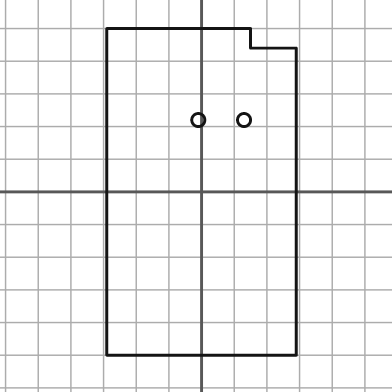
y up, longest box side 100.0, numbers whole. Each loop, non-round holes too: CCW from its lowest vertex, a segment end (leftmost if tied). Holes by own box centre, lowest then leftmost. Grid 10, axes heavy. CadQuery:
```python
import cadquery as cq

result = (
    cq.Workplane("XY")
    .moveTo(-29.0, -50.0)
    .lineTo(29.0, -50.0)
    .lineTo(29.0, 44.0)
    .lineTo(15.0, 44.0)
    .lineTo(15.0, 50.0)
    .lineTo(-29.0, 50.0)
    .close()
    .moveTo(-1.0, 22.0)
    .circle(2.0)
    .moveTo(13.0, 22.0)
    .circle(2.0)
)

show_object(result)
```